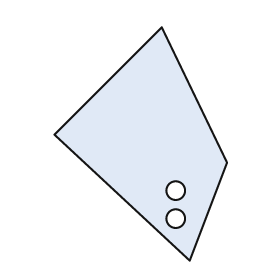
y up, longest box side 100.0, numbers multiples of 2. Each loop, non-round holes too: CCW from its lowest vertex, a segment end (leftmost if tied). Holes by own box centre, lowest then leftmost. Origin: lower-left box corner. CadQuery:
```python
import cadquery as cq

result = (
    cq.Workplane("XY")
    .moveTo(58.0, 0.0)
    .lineTo(74.0, 42.0)
    .lineTo(46.0, 100.0)
    .lineTo(0.0, 54.0)
    .close()
    .moveTo(52.0, 18.0)
    .circle(4.0)
    .moveTo(52.0, 30.0)
    .circle(4.0)
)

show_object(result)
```